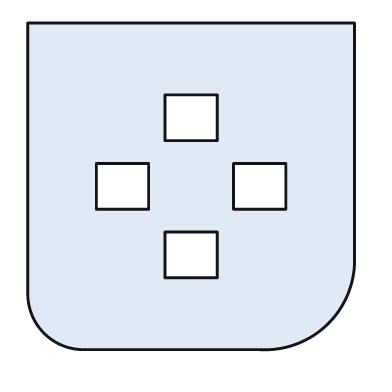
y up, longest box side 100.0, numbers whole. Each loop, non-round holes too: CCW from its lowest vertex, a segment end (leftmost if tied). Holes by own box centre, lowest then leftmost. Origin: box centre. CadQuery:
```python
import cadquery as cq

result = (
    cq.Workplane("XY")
    .moveTo(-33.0, -50.0)
    .lineTo(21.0, -50.0)
    .threePointArc((42.0, -42.0), (50.0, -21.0))
    .lineTo(50.0, 50.0)
    .lineTo(-50.0, 50.0)
    .lineTo(-50.0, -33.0)
    .threePointArc((-45.0, -45.0), (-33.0, -50.0))
    .close()
    .moveTo(-8.0, -28.0)
    .lineTo(8.0, -28.0)
    .lineTo(8.0, -14.0)
    .lineTo(-8.0, -14.0)
    .close()
    .moveTo(-29.0, -7.0)
    .lineTo(-13.0, -7.0)
    .lineTo(-13.0, 7.0)
    .lineTo(-29.0, 7.0)
    .close()
    .moveTo(13.0, -7.0)
    .lineTo(29.0, -7.0)
    .lineTo(29.0, 7.0)
    .lineTo(13.0, 7.0)
    .close()
    .moveTo(-8.0, 14.0)
    .lineTo(8.0, 14.0)
    .lineTo(8.0, 28.0)
    .lineTo(-8.0, 28.0)
    .close()
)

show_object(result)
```